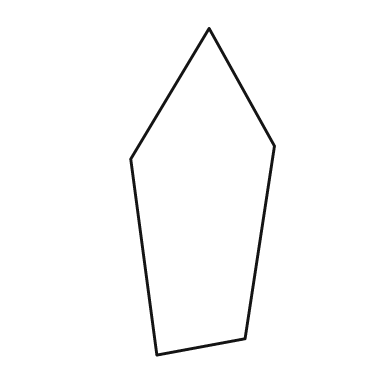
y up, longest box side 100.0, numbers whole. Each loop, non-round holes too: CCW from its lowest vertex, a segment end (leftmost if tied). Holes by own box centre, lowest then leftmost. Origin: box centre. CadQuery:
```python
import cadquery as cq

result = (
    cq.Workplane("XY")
    .moveTo(-14.0, -50.0)
    .lineTo(13.0, -45.0)
    .lineTo(22.0, 14.0)
    .lineTo(2.0, 50.0)
    .lineTo(-22.0, 10.0)
    .close()
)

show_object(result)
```